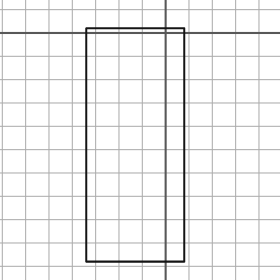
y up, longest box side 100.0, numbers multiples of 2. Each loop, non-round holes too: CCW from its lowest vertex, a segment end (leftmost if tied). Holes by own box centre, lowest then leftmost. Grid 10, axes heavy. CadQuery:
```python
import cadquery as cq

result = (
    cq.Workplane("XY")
    .moveTo(-34.0, -98.0)
    .lineTo(8.0, -98.0)
    .lineTo(8.0, 2.0)
    .lineTo(-34.0, 2.0)
    .close()
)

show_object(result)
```